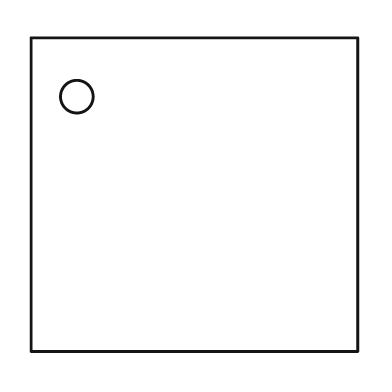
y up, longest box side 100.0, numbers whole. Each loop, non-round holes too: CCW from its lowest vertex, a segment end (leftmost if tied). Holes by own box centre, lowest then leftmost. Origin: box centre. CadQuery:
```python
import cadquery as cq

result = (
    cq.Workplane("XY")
    .moveTo(-50.0, -48.0)
    .lineTo(50.0, -48.0)
    .lineTo(50.0, 48.0)
    .lineTo(-50.0, 48.0)
    .close()
    .moveTo(-36.0, 30.0)
    .circle(5.0)
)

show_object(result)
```